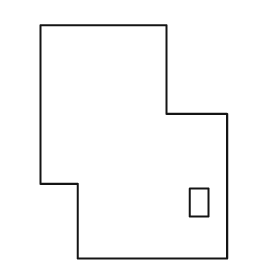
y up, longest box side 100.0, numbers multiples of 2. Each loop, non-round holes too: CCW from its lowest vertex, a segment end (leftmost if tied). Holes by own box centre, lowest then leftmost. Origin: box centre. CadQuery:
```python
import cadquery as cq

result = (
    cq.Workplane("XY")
    .moveTo(-24.0, -50.0)
    .lineTo(40.0, -50.0)
    .lineTo(40.0, 12.0)
    .lineTo(14.0, 12.0)
    .lineTo(14.0, 50.0)
    .lineTo(-40.0, 50.0)
    .lineTo(-40.0, -18.0)
    .lineTo(-24.0, -18.0)
    .close()
    .moveTo(24.0, -32.0)
    .lineTo(32.0, -32.0)
    .lineTo(32.0, -20.0)
    .lineTo(24.0, -20.0)
    .close()
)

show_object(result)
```